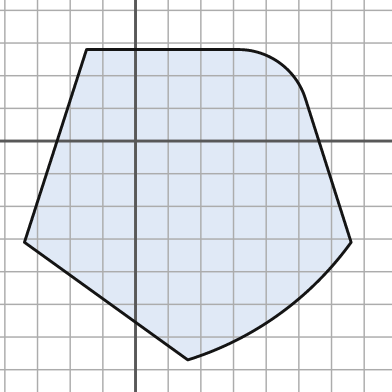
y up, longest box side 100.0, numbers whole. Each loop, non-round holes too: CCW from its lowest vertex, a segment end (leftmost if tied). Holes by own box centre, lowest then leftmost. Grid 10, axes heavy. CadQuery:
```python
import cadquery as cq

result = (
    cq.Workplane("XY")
    .moveTo(16.0, -67.0)
    .threePointArc((44.0, -53.0), (66.0, -31.0))
    .lineTo(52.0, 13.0)
    .threePointArc((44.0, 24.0), (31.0, 28.0))
    .lineTo(-15.0, 28.0)
    .lineTo(-34.0, -31.0)
    .close()
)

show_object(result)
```